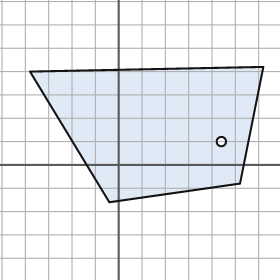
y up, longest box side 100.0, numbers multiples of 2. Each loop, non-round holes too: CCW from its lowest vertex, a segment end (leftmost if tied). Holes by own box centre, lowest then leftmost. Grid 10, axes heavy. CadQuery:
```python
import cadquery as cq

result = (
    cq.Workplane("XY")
    .moveTo(-4.0, -16.0)
    .lineTo(52.0, -8.0)
    .lineTo(62.0, 42.0)
    .lineTo(-38.0, 40.0)
    .close()
    .moveTo(44.0, 10.0)
    .circle(2.0)
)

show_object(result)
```